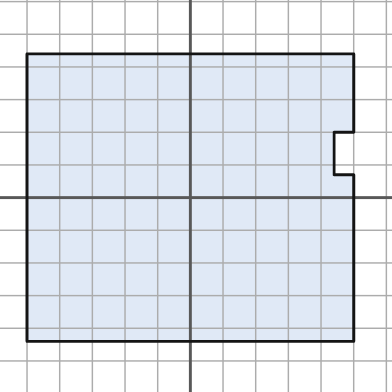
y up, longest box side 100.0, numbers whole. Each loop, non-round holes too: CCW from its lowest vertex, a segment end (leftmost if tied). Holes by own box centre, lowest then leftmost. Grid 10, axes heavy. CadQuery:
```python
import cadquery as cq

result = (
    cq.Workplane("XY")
    .moveTo(-50.0, -44.0)
    .lineTo(50.0, -44.0)
    .lineTo(50.0, 7.0)
    .lineTo(44.0, 7.0)
    .lineTo(44.0, 20.0)
    .lineTo(50.0, 20.0)
    .lineTo(50.0, 44.0)
    .lineTo(-50.0, 44.0)
    .close()
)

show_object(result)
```